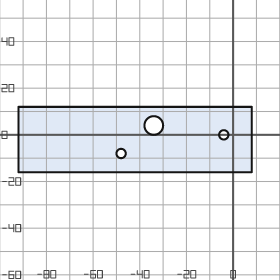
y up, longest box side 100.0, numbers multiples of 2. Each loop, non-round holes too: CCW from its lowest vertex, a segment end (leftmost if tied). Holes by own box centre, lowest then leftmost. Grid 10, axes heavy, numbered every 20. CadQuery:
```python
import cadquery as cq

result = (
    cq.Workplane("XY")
    .moveTo(-92.0, -16.0)
    .lineTo(8.0, -16.0)
    .lineTo(8.0, 12.0)
    .lineTo(-92.0, 12.0)
    .close()
    .moveTo(-48.0, -8.0)
    .circle(2.0)
    .moveTo(-4.0, 0.0)
    .circle(2.0)
    .moveTo(-34.0, 4.0)
    .circle(4.0)
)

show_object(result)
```